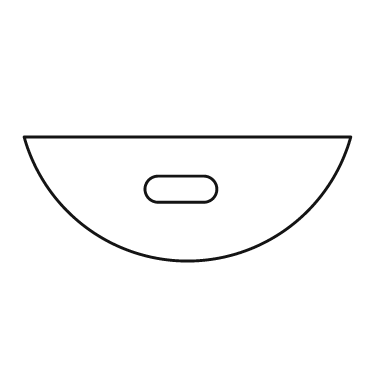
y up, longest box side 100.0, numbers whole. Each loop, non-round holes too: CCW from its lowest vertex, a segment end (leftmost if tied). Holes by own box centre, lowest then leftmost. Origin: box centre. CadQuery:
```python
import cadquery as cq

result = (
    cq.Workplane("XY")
    .moveTo(-50.0, 19.0)
    .threePointArc((0.0, -19.0), (50.0, 19.0))
    .close()
    .moveTo(-9.0, -1.0)
    .lineTo(5.0, -1.0)
    .threePointArc((9.0, 3.0), (5.0, 7.0))
    .lineTo(-9.0, 7.0)
    .threePointArc((-13.0, 3.0), (-9.0, -1.0))
    .close()
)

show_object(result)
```